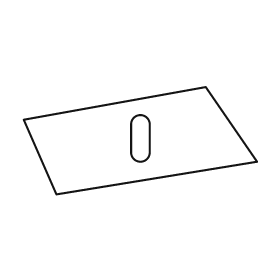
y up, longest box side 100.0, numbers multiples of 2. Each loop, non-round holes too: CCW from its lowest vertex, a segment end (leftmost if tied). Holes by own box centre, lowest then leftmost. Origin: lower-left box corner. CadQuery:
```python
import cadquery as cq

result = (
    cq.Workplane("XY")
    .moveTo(14.0, 0.0)
    .lineTo(100.0, 14.0)
    .lineTo(78.0, 46.0)
    .lineTo(0.0, 32.0)
    .close()
    .moveTo(46.0, 18.0)
    .threePointArc((50.0, 14.0), (54.0, 18.0))
    .lineTo(54.0, 30.0)
    .threePointArc((50.0, 34.0), (46.0, 30.0))
    .close()
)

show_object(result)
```